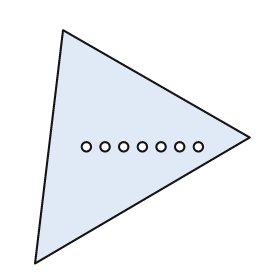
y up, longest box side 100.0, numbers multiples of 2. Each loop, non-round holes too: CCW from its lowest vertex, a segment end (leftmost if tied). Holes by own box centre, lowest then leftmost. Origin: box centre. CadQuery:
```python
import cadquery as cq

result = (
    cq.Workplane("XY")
    .moveTo(-46.0, -50.0)
    .lineTo(46.0, 4.0)
    .lineTo(-34.0, 50.0)
    .close()
    .moveTo(-24.0, 0.0)
    .circle(2.0)
    .moveTo(-16.0, 0.0)
    .circle(2.0)
    .moveTo(-8.0, 0.0)
    .circle(2.0)
    .moveTo(0.0, 0.0)
    .circle(2.0)
    .moveTo(8.0, 0.0)
    .circle(2.0)
    .moveTo(16.0, 0.0)
    .circle(2.0)
    .moveTo(24.0, 0.0)
    .circle(2.0)
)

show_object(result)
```